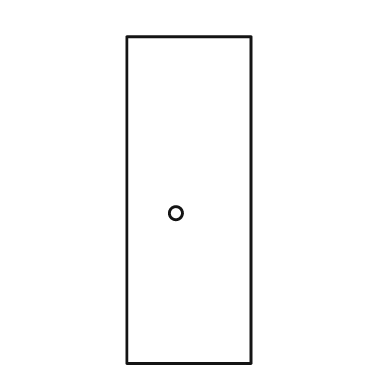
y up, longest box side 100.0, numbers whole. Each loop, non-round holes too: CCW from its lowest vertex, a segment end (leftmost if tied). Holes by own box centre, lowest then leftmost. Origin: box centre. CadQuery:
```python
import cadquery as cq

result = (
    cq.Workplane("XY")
    .moveTo(-19.0, -50.0)
    .lineTo(19.0, -50.0)
    .lineTo(19.0, 50.0)
    .lineTo(-19.0, 50.0)
    .close()
    .moveTo(-4.0, -4.0)
    .circle(2.0)
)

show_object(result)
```